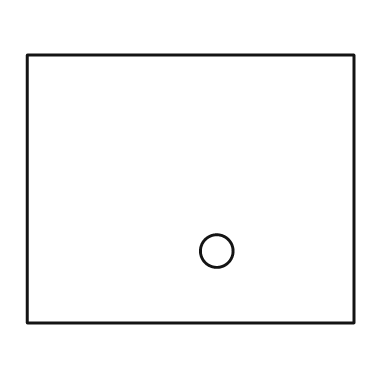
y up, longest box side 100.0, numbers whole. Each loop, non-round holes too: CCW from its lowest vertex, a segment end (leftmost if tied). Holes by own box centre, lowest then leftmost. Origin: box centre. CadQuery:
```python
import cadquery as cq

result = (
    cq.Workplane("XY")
    .moveTo(-50.0, -41.0)
    .lineTo(50.0, -41.0)
    .lineTo(50.0, 41.0)
    .lineTo(-50.0, 41.0)
    .close()
    .moveTo(8.0, -19.0)
    .circle(5.0)
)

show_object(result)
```